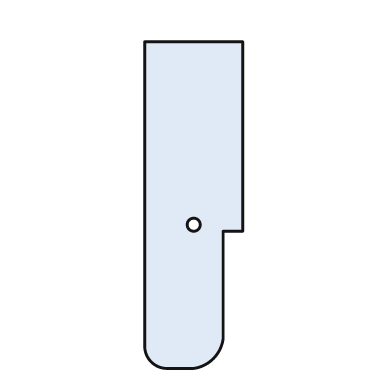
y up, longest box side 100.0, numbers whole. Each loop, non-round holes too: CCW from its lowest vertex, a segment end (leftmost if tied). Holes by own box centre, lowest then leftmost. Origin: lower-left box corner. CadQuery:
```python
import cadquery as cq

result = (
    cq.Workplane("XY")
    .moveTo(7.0, 0.0)
    .lineTo(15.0, 0.0)
    .threePointArc((21.0, 3.0), (24.0, 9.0))
    .lineTo(24.0, 42.0)
    .lineTo(30.0, 42.0)
    .lineTo(30.0, 100.0)
    .lineTo(0.0, 100.0)
    .lineTo(0.0, 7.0)
    .threePointArc((2.0, 2.0), (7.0, 0.0))
    .close()
    .moveTo(15.0, 44.0)
    .circle(2.0)
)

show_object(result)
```